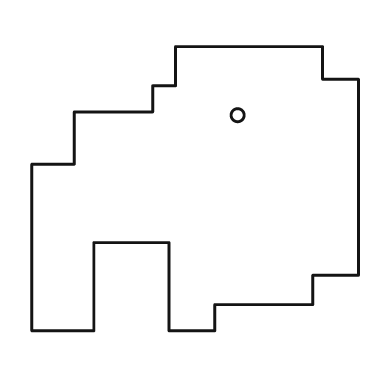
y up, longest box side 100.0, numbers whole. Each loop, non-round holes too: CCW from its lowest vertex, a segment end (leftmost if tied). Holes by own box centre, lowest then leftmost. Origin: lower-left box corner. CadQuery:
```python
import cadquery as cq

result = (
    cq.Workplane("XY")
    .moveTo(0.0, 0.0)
    .lineTo(19.0, 0.0)
    .lineTo(19.0, 27.0)
    .lineTo(42.0, 27.0)
    .lineTo(42.0, 0.0)
    .lineTo(56.0, 0.0)
    .lineTo(56.0, 8.0)
    .lineTo(86.0, 8.0)
    .lineTo(86.0, 17.0)
    .lineTo(100.0, 17.0)
    .lineTo(100.0, 77.0)
    .lineTo(89.0, 77.0)
    .lineTo(89.0, 87.0)
    .lineTo(44.0, 87.0)
    .lineTo(44.0, 75.0)
    .lineTo(37.0, 75.0)
    .lineTo(37.0, 67.0)
    .lineTo(13.0, 67.0)
    .lineTo(13.0, 51.0)
    .lineTo(0.0, 51.0)
    .close()
    .moveTo(63.0, 66.0)
    .circle(2.0)
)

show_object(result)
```